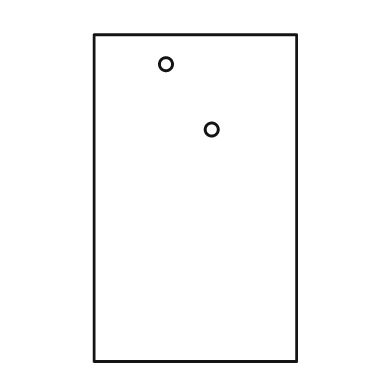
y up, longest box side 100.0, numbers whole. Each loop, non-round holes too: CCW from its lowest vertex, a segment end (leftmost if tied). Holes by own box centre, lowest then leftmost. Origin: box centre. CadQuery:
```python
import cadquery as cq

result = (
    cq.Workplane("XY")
    .moveTo(-31.0, -50.0)
    .lineTo(31.0, -50.0)
    .lineTo(31.0, 50.0)
    .lineTo(-31.0, 50.0)
    .close()
    .moveTo(5.0, 21.0)
    .circle(2.0)
    .moveTo(-9.0, 41.0)
    .circle(2.0)
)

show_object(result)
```